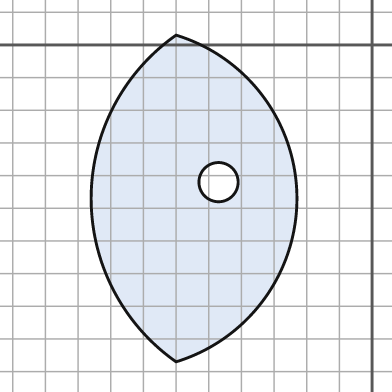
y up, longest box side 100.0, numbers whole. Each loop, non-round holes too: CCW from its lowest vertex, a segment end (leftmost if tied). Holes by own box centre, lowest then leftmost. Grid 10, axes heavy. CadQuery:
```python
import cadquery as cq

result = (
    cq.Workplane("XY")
    .moveTo(-60.0, -97.0)
    .threePointArc((-23.0, -47.0), (-60.0, 3.0))
    .threePointArc((-86.0, -47.0), (-60.0, -97.0))
    .close()
    .moveTo(-47.0, -42.0)
    .circle(6.0)
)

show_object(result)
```